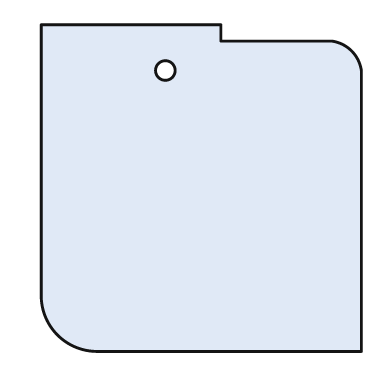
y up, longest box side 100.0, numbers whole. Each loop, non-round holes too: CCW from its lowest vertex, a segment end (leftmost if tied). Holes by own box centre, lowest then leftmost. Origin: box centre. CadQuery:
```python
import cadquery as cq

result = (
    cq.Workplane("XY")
    .moveTo(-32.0, -50.0)
    .lineTo(49.0, -50.0)
    .lineTo(49.0, 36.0)
    .threePointArc((46.0, 42.0), (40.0, 45.0))
    .lineTo(6.0, 45.0)
    .lineTo(6.0, 50.0)
    .lineTo(-49.0, 50.0)
    .lineTo(-49.0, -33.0)
    .threePointArc((-44.0, -45.0), (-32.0, -50.0))
    .close()
    .moveTo(-11.0, 36.0)
    .circle(3.0)
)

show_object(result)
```